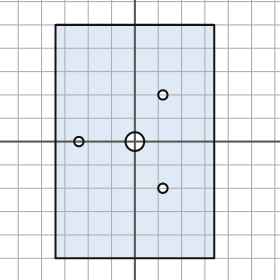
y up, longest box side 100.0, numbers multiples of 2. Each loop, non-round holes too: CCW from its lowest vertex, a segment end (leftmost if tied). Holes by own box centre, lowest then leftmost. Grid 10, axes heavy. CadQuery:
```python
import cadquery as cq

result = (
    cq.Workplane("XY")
    .moveTo(-34.0, -50.0)
    .lineTo(34.0, -50.0)
    .lineTo(34.0, 50.0)
    .lineTo(-34.0, 50.0)
    .close()
    .moveTo(12.0, -20.0)
    .circle(2.0)
    .moveTo(-24.0, 0.0)
    .circle(2.0)
    .moveTo(0.0, 0.0)
    .circle(4.0)
    .moveTo(12.0, 20.0)
    .circle(2.0)
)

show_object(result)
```